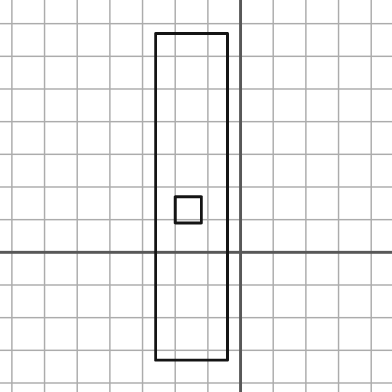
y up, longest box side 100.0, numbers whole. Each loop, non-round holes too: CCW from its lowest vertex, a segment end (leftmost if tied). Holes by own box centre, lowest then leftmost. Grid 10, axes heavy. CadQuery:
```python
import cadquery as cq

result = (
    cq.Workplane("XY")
    .moveTo(-26.0, -33.0)
    .lineTo(-4.0, -33.0)
    .lineTo(-4.0, 67.0)
    .lineTo(-26.0, 67.0)
    .close()
    .moveTo(-20.0, 9.0)
    .lineTo(-12.0, 9.0)
    .lineTo(-12.0, 17.0)
    .lineTo(-20.0, 17.0)
    .close()
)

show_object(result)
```